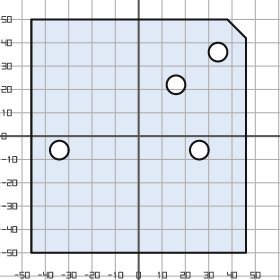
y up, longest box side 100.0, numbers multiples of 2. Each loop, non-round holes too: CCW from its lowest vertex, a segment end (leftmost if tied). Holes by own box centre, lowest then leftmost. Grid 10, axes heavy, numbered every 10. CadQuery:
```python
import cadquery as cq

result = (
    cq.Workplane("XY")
    .moveTo(-46.0, -50.0)
    .lineTo(46.0, -50.0)
    .lineTo(46.0, 42.0)
    .lineTo(38.0, 50.0)
    .lineTo(-46.0, 50.0)
    .close()
    .moveTo(-34.0, -6.0)
    .circle(4.0)
    .moveTo(26.0, -6.0)
    .circle(4.0)
    .moveTo(16.0, 22.0)
    .circle(4.0)
    .moveTo(34.0, 36.0)
    .circle(4.0)
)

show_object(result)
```